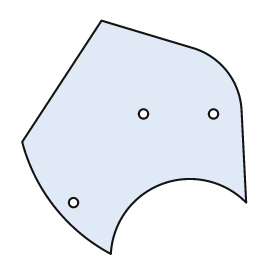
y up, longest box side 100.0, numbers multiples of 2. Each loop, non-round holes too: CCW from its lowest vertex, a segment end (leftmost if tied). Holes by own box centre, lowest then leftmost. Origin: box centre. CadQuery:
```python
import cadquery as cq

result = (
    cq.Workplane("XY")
    .moveTo(-10.0, -50.0)
    .threePointArc((12.0, -20.0), (48.0, -28.0))
    .lineTo(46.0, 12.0)
    .threePointArc((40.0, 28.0), (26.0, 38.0))
    .lineTo(-14.0, 50.0)
    .lineTo(-48.0, -2.0)
    .threePointArc((-34.0, -30.0), (-10.0, -50.0))
    .close()
    .moveTo(-26.0, -28.0)
    .circle(2.0)
    .moveTo(4.0, 10.0)
    .circle(2.0)
    .moveTo(34.0, 10.0)
    .circle(2.0)
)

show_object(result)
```